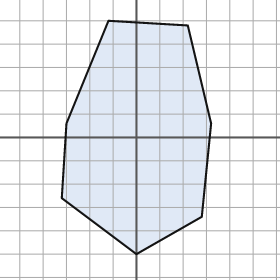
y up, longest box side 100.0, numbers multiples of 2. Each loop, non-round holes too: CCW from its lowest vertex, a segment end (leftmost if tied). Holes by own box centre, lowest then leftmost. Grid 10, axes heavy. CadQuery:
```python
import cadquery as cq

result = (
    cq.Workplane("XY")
    .moveTo(0.0, -50.0)
    .lineTo(28.0, -34.0)
    .lineTo(32.0, 6.0)
    .lineTo(22.0, 48.0)
    .lineTo(-12.0, 50.0)
    .lineTo(-30.0, 6.0)
    .lineTo(-32.0, -26.0)
    .close()
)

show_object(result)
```